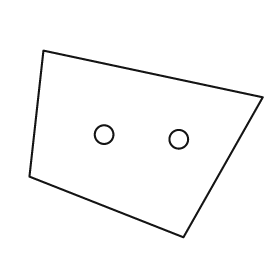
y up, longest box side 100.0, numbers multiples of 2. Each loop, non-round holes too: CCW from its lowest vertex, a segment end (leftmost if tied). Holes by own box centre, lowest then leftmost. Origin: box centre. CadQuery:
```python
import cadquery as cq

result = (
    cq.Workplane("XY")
    .moveTo(16.0, -40.0)
    .lineTo(50.0, 20.0)
    .lineTo(-44.0, 40.0)
    .lineTo(-50.0, -14.0)
    .close()
    .moveTo(14.0, 2.0)
    .circle(4.0)
    .moveTo(-18.0, 4.0)
    .circle(4.0)
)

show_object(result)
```